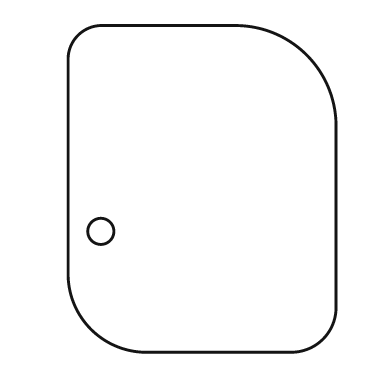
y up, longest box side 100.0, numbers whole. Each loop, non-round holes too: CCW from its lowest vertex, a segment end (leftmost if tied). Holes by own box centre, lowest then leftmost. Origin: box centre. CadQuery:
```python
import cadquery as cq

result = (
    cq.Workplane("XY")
    .moveTo(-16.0, -50.0)
    .lineTo(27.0, -50.0)
    .threePointArc((37.0, -46.0), (41.0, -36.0))
    .lineTo(41.0, 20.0)
    .threePointArc((32.0, 41.0), (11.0, 50.0))
    .lineTo(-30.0, 50.0)
    .threePointArc((-38.0, 47.0), (-41.0, 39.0))
    .lineTo(-41.0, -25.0)
    .threePointArc((-34.0, -43.0), (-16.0, -50.0))
    .close()
    .moveTo(-31.0, -13.0)
    .circle(4.0)
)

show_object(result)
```